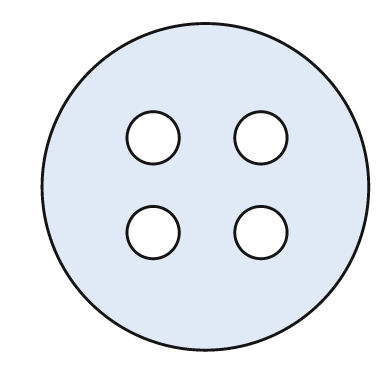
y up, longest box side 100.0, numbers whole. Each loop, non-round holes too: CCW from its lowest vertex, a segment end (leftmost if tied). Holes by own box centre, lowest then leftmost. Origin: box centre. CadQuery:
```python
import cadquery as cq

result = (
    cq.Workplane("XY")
    .moveTo(0.0, 0.0)
    .circle(50.0)
    .moveTo(-16.0, -14.0)
    .circle(8.0)
    .moveTo(17.0, -14.0)
    .circle(8.0)
    .moveTo(-16.0, 15.0)
    .circle(8.0)
    .moveTo(17.0, 15.0)
    .circle(8.0)
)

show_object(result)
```